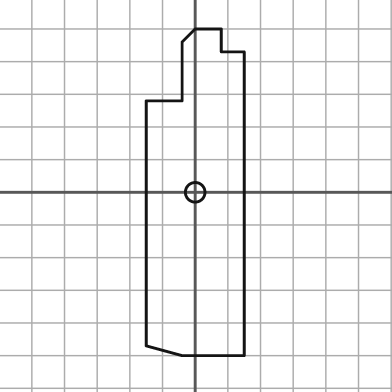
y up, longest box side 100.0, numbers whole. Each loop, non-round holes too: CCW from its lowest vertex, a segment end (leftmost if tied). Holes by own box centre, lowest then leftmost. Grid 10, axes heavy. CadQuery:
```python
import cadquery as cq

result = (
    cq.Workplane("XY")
    .moveTo(-4.0, -50.0)
    .lineTo(15.0, -50.0)
    .lineTo(15.0, 43.0)
    .lineTo(8.0, 43.0)
    .lineTo(8.0, 50.0)
    .lineTo(0.0, 50.0)
    .lineTo(-4.0, 46.0)
    .lineTo(-4.0, 28.0)
    .lineTo(-15.0, 28.0)
    .lineTo(-15.0, -47.0)
    .close()
    .moveTo(0.0, 0.0)
    .circle(3.0)
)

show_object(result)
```